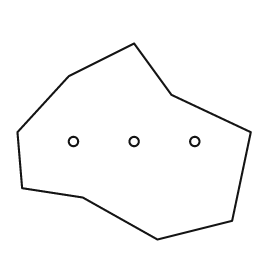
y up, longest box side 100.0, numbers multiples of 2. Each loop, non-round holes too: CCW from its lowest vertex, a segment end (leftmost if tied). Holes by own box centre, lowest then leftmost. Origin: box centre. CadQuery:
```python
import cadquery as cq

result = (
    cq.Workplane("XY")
    .moveTo(10.0, -42.0)
    .lineTo(42.0, -34.0)
    .lineTo(50.0, 4.0)
    .lineTo(16.0, 20.0)
    .lineTo(0.0, 42.0)
    .lineTo(-28.0, 28.0)
    .lineTo(-50.0, 4.0)
    .lineTo(-48.0, -20.0)
    .lineTo(-22.0, -24.0)
    .close()
    .moveTo(-26.0, 0.0)
    .circle(2.0)
    .moveTo(0.0, 0.0)
    .circle(2.0)
    .moveTo(26.0, 0.0)
    .circle(2.0)
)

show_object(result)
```